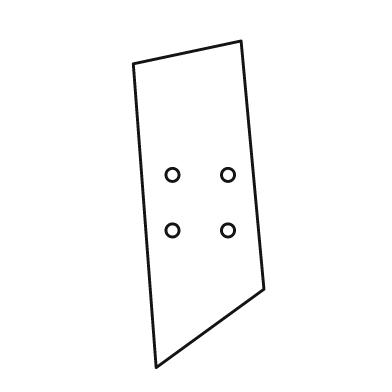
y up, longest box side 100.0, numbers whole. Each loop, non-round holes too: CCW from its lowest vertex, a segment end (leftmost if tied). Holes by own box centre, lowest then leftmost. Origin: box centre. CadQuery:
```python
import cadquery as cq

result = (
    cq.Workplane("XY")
    .moveTo(-13.0, -50.0)
    .lineTo(20.0, -26.0)
    .lineTo(13.0, 50.0)
    .lineTo(-20.0, 43.0)
    .close()
    .moveTo(-8.0, -8.0)
    .circle(2.0)
    .moveTo(9.0, -8.0)
    .circle(2.0)
    .moveTo(-8.0, 9.0)
    .circle(2.0)
    .moveTo(9.0, 9.0)
    .circle(2.0)
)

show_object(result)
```